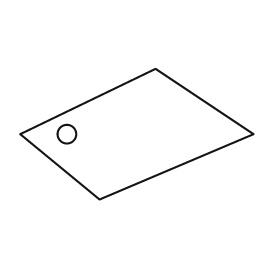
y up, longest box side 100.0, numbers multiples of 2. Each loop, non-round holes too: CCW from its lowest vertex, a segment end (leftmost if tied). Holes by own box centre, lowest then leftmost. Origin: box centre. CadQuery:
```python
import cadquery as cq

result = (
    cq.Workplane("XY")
    .moveTo(-16.0, -28.0)
    .lineTo(50.0, 0.0)
    .lineTo(8.0, 28.0)
    .lineTo(-50.0, 0.0)
    .close()
    .moveTo(-30.0, 0.0)
    .circle(4.0)
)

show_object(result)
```